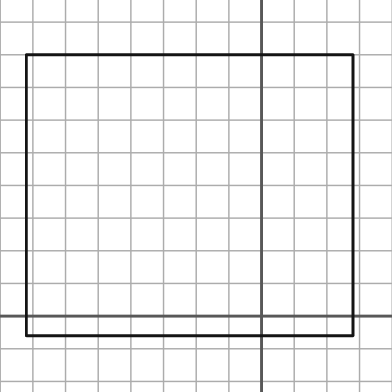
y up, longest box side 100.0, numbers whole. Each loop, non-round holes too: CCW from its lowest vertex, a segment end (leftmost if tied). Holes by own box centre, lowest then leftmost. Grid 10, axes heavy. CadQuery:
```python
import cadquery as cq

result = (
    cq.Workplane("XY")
    .moveTo(-72.0, -6.0)
    .lineTo(28.0, -6.0)
    .lineTo(28.0, 80.0)
    .lineTo(-72.0, 80.0)
    .close()
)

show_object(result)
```